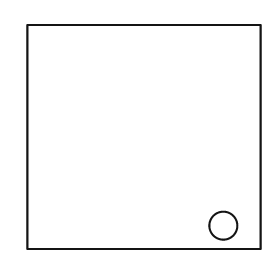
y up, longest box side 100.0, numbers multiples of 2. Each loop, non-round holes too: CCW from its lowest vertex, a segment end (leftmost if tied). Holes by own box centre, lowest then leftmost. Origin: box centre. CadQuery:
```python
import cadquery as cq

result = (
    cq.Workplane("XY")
    .moveTo(-50.0, -48.0)
    .lineTo(50.0, -48.0)
    .lineTo(50.0, 48.0)
    .lineTo(-50.0, 48.0)
    .close()
    .moveTo(34.0, -38.0)
    .circle(6.0)
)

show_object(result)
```